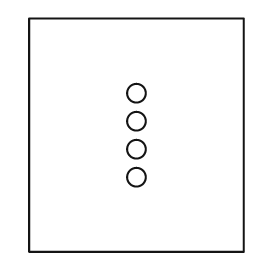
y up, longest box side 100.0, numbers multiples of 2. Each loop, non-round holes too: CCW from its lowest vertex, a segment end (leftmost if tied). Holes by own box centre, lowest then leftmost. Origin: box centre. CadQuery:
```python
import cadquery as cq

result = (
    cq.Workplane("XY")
    .moveTo(-46.0, -50.0)
    .lineTo(46.0, -50.0)
    .lineTo(46.0, 50.0)
    .lineTo(-46.0, 50.0)
    .close()
    .moveTo(0.0, -18.0)
    .circle(4.0)
    .moveTo(0.0, -6.0)
    .circle(4.0)
    .moveTo(0.0, 6.0)
    .circle(4.0)
    .moveTo(0.0, 18.0)
    .circle(4.0)
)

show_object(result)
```